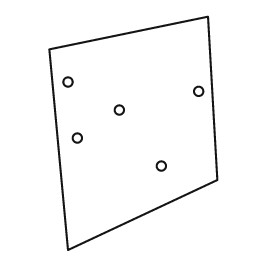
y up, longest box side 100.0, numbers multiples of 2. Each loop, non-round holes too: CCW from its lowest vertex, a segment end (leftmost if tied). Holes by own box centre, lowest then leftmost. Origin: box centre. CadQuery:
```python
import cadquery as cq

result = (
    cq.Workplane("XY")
    .moveTo(-28.0, -50.0)
    .lineTo(36.0, -20.0)
    .lineTo(32.0, 50.0)
    .lineTo(-36.0, 36.0)
    .close()
    .moveTo(12.0, -14.0)
    .circle(2.0)
    .moveTo(-24.0, -2.0)
    .circle(2.0)
    .moveTo(-6.0, 10.0)
    .circle(2.0)
    .moveTo(28.0, 18.0)
    .circle(2.0)
    .moveTo(-28.0, 22.0)
    .circle(2.0)
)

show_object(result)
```